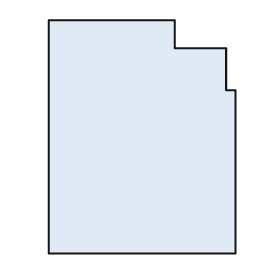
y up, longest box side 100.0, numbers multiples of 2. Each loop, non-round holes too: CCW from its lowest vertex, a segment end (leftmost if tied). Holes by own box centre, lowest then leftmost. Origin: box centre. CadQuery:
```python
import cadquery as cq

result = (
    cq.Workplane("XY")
    .moveTo(-40.0, -50.0)
    .lineTo(40.0, -50.0)
    .lineTo(40.0, 20.0)
    .lineTo(36.0, 20.0)
    .lineTo(36.0, 38.0)
    .lineTo(14.0, 38.0)
    .lineTo(14.0, 50.0)
    .lineTo(-40.0, 50.0)
    .close()
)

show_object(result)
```